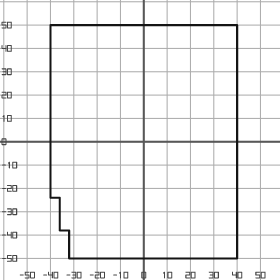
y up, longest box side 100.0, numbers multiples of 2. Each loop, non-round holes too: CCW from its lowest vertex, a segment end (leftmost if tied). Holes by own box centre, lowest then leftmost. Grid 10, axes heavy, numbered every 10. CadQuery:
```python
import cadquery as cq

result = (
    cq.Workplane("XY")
    .moveTo(-32.0, -50.0)
    .lineTo(40.0, -50.0)
    .lineTo(40.0, 50.0)
    .lineTo(-40.0, 50.0)
    .lineTo(-40.0, -24.0)
    .lineTo(-36.0, -24.0)
    .lineTo(-36.0, -38.0)
    .lineTo(-32.0, -38.0)
    .close()
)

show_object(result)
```